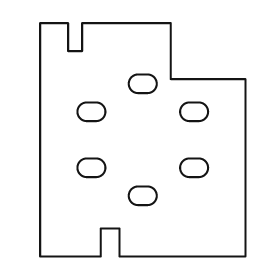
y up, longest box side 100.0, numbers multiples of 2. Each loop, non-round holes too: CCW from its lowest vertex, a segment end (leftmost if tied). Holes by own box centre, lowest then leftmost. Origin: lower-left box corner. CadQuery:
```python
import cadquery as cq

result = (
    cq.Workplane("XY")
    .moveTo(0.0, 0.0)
    .lineTo(26.0, 0.0)
    .lineTo(26.0, 12.0)
    .lineTo(34.0, 12.0)
    .lineTo(34.0, 0.0)
    .lineTo(88.0, 0.0)
    .lineTo(88.0, 76.0)
    .lineTo(56.0, 76.0)
    .lineTo(56.0, 100.0)
    .lineTo(18.0, 100.0)
    .lineTo(18.0, 88.0)
    .lineTo(12.0, 88.0)
    .lineTo(12.0, 100.0)
    .lineTo(0.0, 100.0)
    .close()
    .moveTo(42.0, 22.0)
    .lineTo(46.0, 22.0)
    .threePointArc((50.0, 26.0), (46.0, 30.0))
    .lineTo(42.0, 30.0)
    .threePointArc((38.0, 26.0), (42.0, 22.0))
    .close()
    .moveTo(20.0, 34.0)
    .lineTo(24.0, 34.0)
    .threePointArc((28.0, 38.0), (24.0, 42.0))
    .lineTo(20.0, 42.0)
    .threePointArc((16.0, 38.0), (20.0, 34.0))
    .close()
    .moveTo(64.0, 34.0)
    .lineTo(68.0, 34.0)
    .threePointArc((72.0, 38.0), (68.0, 42.0))
    .lineTo(64.0, 42.0)
    .threePointArc((60.0, 38.0), (64.0, 34.0))
    .close()
    .moveTo(20.0, 58.0)
    .lineTo(24.0, 58.0)
    .threePointArc((28.0, 62.0), (24.0, 66.0))
    .lineTo(20.0, 66.0)
    .threePointArc((16.0, 62.0), (20.0, 58.0))
    .close()
    .moveTo(64.0, 58.0)
    .lineTo(68.0, 58.0)
    .threePointArc((72.0, 62.0), (68.0, 66.0))
    .lineTo(64.0, 66.0)
    .threePointArc((60.0, 62.0), (64.0, 58.0))
    .close()
    .moveTo(42.0, 70.0)
    .lineTo(46.0, 70.0)
    .threePointArc((50.0, 74.0), (46.0, 78.0))
    .lineTo(42.0, 78.0)
    .threePointArc((38.0, 74.0), (42.0, 70.0))
    .close()
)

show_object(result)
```